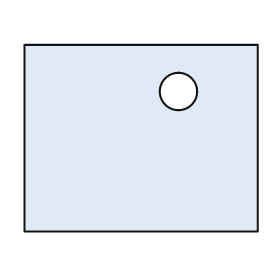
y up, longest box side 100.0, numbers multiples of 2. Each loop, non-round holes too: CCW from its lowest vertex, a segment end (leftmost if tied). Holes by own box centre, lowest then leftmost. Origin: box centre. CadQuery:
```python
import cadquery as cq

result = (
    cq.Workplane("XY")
    .moveTo(-50.0, -40.0)
    .lineTo(50.0, -40.0)
    .lineTo(50.0, 40.0)
    .lineTo(-50.0, 40.0)
    .close()
    .moveTo(16.0, 20.0)
    .circle(8.0)
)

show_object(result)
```